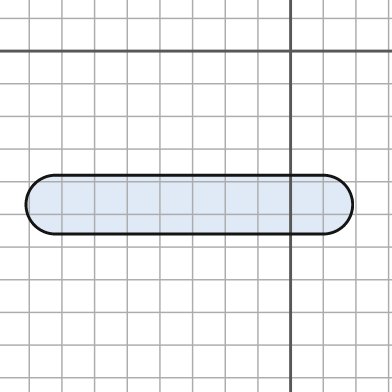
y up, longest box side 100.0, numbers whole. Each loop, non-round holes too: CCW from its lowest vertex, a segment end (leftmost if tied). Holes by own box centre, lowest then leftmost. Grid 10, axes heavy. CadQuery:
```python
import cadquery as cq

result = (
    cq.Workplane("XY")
    .moveTo(-72.0, -56.0)
    .lineTo(10.0, -56.0)
    .threePointArc((19.0, -47.0), (10.0, -38.0))
    .lineTo(-72.0, -38.0)
    .threePointArc((-81.0, -47.0), (-72.0, -56.0))
    .close()
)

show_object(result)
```